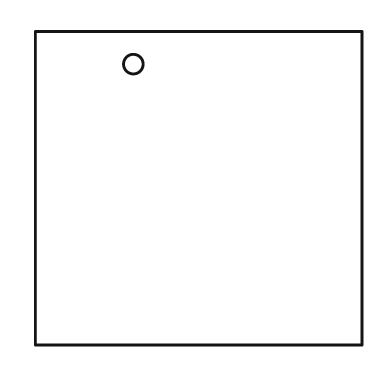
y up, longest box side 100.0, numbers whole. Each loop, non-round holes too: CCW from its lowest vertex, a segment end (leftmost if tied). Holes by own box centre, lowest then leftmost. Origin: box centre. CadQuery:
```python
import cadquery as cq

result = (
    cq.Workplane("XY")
    .moveTo(-50.0, -48.0)
    .lineTo(50.0, -48.0)
    .lineTo(50.0, 48.0)
    .lineTo(-50.0, 48.0)
    .close()
    .moveTo(-20.0, 38.0)
    .circle(3.0)
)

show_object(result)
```